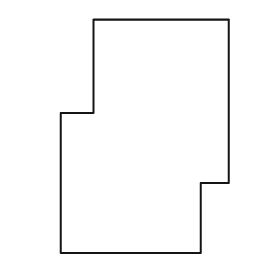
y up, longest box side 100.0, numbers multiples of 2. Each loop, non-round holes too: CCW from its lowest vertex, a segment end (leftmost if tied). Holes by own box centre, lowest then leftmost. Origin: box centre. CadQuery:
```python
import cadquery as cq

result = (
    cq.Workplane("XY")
    .moveTo(-36.0, -50.0)
    .lineTo(24.0, -50.0)
    .lineTo(24.0, -20.0)
    .lineTo(36.0, -20.0)
    .lineTo(36.0, 50.0)
    .lineTo(-22.0, 50.0)
    .lineTo(-22.0, 10.0)
    .lineTo(-36.0, 10.0)
    .close()
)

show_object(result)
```